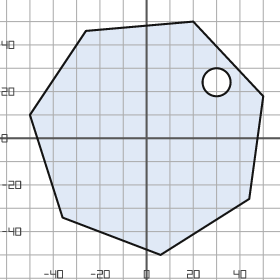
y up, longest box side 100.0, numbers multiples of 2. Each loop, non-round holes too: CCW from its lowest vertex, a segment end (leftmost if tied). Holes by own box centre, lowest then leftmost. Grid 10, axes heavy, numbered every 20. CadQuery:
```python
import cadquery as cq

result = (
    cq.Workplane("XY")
    .moveTo(6.0, -50.0)
    .lineTo(44.0, -26.0)
    .lineTo(50.0, 18.0)
    .lineTo(20.0, 50.0)
    .lineTo(-26.0, 46.0)
    .lineTo(-50.0, 10.0)
    .lineTo(-36.0, -34.0)
    .close()
    .moveTo(30.0, 24.0)
    .circle(6.0)
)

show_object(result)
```